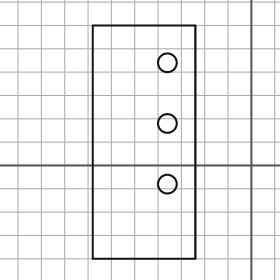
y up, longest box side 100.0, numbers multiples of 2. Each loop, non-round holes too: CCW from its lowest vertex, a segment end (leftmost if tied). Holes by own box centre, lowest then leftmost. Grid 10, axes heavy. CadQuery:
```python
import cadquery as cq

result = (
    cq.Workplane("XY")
    .moveTo(-68.0, -40.0)
    .lineTo(-24.0, -40.0)
    .lineTo(-24.0, 60.0)
    .lineTo(-68.0, 60.0)
    .close()
    .moveTo(-36.0, -8.0)
    .circle(4.0)
    .moveTo(-36.0, 18.0)
    .circle(4.0)
    .moveTo(-36.0, 44.0)
    .circle(4.0)
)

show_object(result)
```